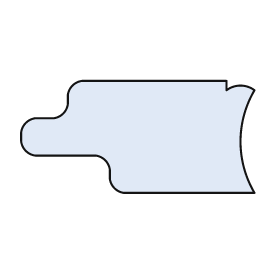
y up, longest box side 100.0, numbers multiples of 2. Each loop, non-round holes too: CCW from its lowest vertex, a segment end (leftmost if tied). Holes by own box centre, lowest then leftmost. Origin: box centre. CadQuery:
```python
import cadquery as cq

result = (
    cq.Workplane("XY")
    .moveTo(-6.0, -24.0)
    .lineTo(50.0, -24.0)
    .threePointArc((44.0, -2.0), (50.0, 20.0))
    .threePointArc((44.0, 22.0), (38.0, 20.0))
    .lineTo(38.0, 24.0)
    .lineTo(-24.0, 24.0)
    .threePointArc((-28.0, 22.0), (-30.0, 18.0))
    .lineTo(-30.0, 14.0)
    .threePointArc((-32.0, 10.0), (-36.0, 8.0))
    .lineTo(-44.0, 8.0)
    .threePointArc((-48.0, 6.0), (-50.0, 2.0))
    .lineTo(-50.0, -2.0)
    .threePointArc((-48.0, -6.0), (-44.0, -8.0))
    .lineTo(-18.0, -8.0)
    .threePointArc((-14.0, -10.0), (-12.0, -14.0))
    .lineTo(-12.0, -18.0)
    .threePointArc((-10.0, -22.0), (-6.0, -24.0))
    .close()
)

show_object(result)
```